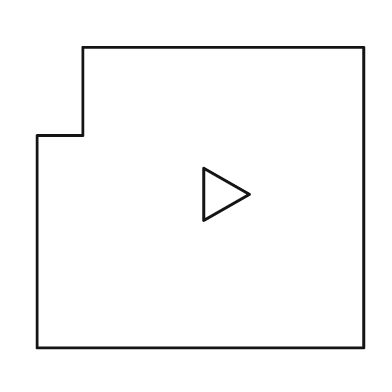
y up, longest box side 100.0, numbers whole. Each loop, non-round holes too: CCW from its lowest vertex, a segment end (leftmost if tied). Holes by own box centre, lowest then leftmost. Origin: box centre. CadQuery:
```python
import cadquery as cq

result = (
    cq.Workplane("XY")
    .moveTo(-50.0, -46.0)
    .lineTo(50.0, -46.0)
    .lineTo(50.0, 46.0)
    .lineTo(-36.0, 46.0)
    .lineTo(-36.0, 19.0)
    .lineTo(-50.0, 19.0)
    .close()
    .moveTo(1.0, -7.0)
    .lineTo(15.0, 1.0)
    .lineTo(1.0, 9.0)
    .close()
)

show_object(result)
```